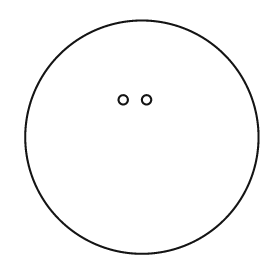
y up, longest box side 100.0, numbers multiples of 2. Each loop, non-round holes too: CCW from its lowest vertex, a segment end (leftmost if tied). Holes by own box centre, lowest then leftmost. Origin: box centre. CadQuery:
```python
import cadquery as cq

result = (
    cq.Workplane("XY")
    .moveTo(0.0, 0.0)
    .circle(50.0)
    .moveTo(-8.0, 16.0)
    .circle(2.0)
    .moveTo(2.0, 16.0)
    .circle(2.0)
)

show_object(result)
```